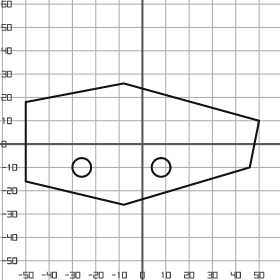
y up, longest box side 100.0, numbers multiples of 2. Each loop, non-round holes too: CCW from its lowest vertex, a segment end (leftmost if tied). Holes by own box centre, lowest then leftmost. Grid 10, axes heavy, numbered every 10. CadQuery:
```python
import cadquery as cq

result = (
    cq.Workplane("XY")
    .moveTo(-8.0, -26.0)
    .lineTo(46.0, -10.0)
    .lineTo(50.0, 10.0)
    .lineTo(-8.0, 26.0)
    .lineTo(-50.0, 18.0)
    .lineTo(-50.0, -16.0)
    .close()
    .moveTo(-26.0, -10.0)
    .circle(4.0)
    .moveTo(8.0, -10.0)
    .circle(4.0)
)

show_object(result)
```